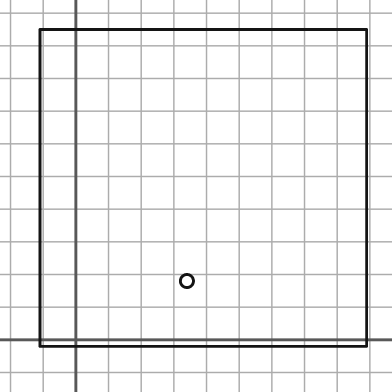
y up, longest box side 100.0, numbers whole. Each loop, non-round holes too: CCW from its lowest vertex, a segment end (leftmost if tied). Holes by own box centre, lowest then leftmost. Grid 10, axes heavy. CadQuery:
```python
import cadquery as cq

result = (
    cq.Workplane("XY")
    .moveTo(-11.0, -2.0)
    .lineTo(89.0, -2.0)
    .lineTo(89.0, 95.0)
    .lineTo(-11.0, 95.0)
    .close()
    .moveTo(34.0, 18.0)
    .circle(2.0)
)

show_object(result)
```